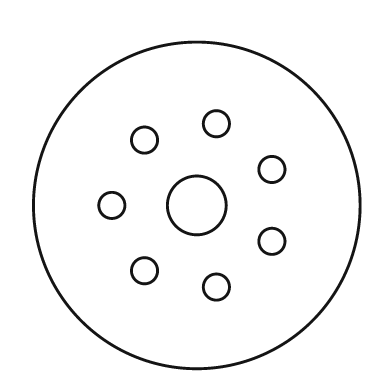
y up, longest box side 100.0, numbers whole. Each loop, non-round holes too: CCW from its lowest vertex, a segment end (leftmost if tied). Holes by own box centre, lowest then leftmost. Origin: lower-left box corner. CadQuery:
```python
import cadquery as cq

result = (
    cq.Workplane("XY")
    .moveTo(50.0, 50.0)
    .circle(50.0)
    .moveTo(56.0, 25.0)
    .circle(4.0)
    .moveTo(34.0, 30.0)
    .circle(4.0)
    .moveTo(73.0, 39.0)
    .circle(4.0)
    .moveTo(24.0, 50.0)
    .circle(4.0)
    .moveTo(50.0, 50.0)
    .circle(9.0)
    .moveTo(73.0, 61.0)
    .circle(4.0)
    .moveTo(34.0, 70.0)
    .circle(4.0)
    .moveTo(56.0, 75.0)
    .circle(4.0)
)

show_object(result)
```